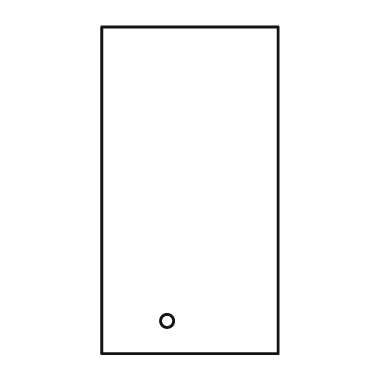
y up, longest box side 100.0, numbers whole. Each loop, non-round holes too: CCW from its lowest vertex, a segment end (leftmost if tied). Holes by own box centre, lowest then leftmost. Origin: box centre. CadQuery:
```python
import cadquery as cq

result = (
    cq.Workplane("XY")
    .moveTo(-27.0, -50.0)
    .lineTo(27.0, -50.0)
    .lineTo(27.0, 50.0)
    .lineTo(-27.0, 50.0)
    .close()
    .moveTo(-7.0, -40.0)
    .circle(2.0)
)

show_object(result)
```